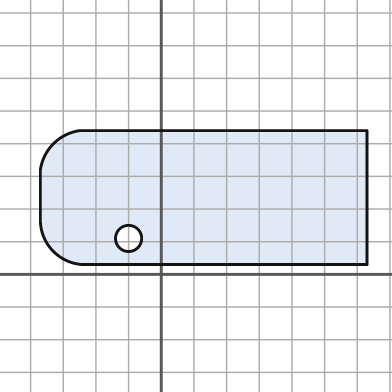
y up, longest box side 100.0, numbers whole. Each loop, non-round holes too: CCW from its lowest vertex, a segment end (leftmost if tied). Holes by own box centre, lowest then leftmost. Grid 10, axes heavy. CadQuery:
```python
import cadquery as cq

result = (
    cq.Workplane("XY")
    .moveTo(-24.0, 3.0)
    .lineTo(63.0, 3.0)
    .lineTo(63.0, 44.0)
    .lineTo(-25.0, 44.0)
    .threePointArc((-33.0, 40.0), (-37.0, 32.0))
    .lineTo(-37.0, 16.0)
    .threePointArc((-33.0, 7.0), (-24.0, 3.0))
    .close()
    .moveTo(-10.0, 11.0)
    .circle(4.0)
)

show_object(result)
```